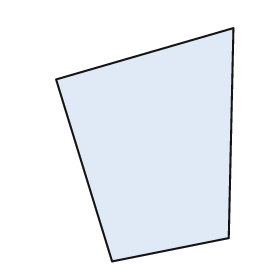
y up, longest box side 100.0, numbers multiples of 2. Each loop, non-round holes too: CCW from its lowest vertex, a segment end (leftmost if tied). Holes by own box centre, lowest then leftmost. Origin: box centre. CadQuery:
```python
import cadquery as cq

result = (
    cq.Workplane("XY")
    .moveTo(-14.0, -50.0)
    .lineTo(36.0, -40.0)
    .lineTo(38.0, 50.0)
    .lineTo(-38.0, 28.0)
    .close()
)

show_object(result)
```